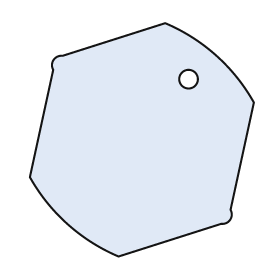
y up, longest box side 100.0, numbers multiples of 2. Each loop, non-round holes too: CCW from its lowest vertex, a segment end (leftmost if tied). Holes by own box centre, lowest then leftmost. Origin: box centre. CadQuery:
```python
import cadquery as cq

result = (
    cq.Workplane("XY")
    .moveTo(-10.0, -50.0)
    .lineTo(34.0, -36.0)
    .threePointArc((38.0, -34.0), (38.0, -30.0))
    .lineTo(48.0, 16.0)
    .threePointArc((32.0, 36.0), (10.0, 50.0))
    .lineTo(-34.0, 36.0)
    .threePointArc((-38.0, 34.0), (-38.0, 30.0))
    .lineTo(-48.0, -16.0)
    .threePointArc((-32.0, -36.0), (-10.0, -50.0))
    .close()
    .moveTo(20.0, 26.0)
    .circle(4.0)
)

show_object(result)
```